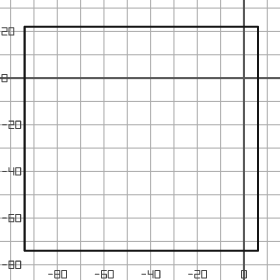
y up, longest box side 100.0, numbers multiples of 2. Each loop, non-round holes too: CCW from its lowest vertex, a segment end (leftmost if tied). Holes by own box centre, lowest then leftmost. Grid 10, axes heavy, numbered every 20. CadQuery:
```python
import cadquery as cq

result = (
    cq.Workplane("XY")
    .moveTo(-94.0, -74.0)
    .lineTo(6.0, -74.0)
    .lineTo(6.0, 22.0)
    .lineTo(-94.0, 22.0)
    .close()
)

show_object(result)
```